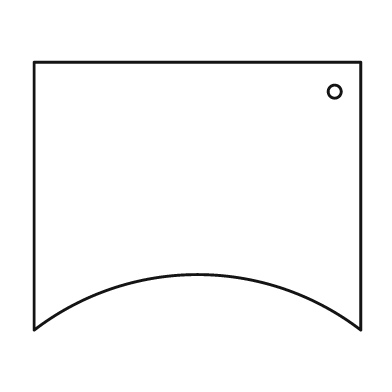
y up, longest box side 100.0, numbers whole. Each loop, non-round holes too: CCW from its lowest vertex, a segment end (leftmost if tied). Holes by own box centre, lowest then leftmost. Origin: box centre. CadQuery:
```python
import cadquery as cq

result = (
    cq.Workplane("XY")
    .moveTo(-50.0, -41.0)
    .threePointArc((0.0, -24.0), (50.0, -41.0))
    .lineTo(50.0, 41.0)
    .lineTo(-50.0, 41.0)
    .close()
    .moveTo(42.0, 32.0)
    .circle(2.0)
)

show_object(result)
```